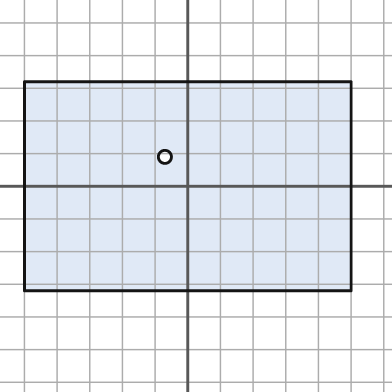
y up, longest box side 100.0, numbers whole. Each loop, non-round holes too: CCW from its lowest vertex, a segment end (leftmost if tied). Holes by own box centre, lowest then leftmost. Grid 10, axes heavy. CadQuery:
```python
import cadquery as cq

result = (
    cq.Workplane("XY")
    .moveTo(-50.0, -32.0)
    .lineTo(50.0, -32.0)
    .lineTo(50.0, 32.0)
    .lineTo(-50.0, 32.0)
    .close()
    .moveTo(-7.0, 9.0)
    .circle(2.0)
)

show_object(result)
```